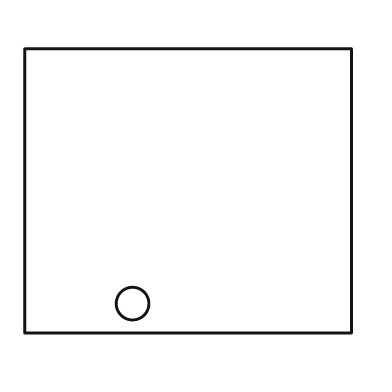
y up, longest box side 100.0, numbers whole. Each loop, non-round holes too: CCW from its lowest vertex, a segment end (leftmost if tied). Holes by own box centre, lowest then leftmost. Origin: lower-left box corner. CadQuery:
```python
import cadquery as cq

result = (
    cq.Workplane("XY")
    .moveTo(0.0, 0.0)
    .lineTo(100.0, 0.0)
    .lineTo(100.0, 87.0)
    .lineTo(0.0, 87.0)
    .close()
    .moveTo(33.0, 9.0)
    .circle(5.0)
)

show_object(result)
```